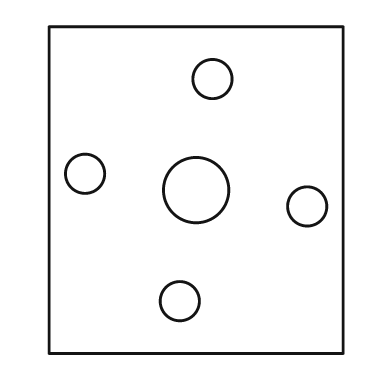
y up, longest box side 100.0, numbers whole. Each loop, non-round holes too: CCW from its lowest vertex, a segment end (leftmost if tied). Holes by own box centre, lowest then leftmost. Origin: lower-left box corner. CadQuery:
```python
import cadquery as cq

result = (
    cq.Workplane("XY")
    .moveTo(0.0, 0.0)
    .lineTo(90.0, 0.0)
    .lineTo(90.0, 100.0)
    .lineTo(0.0, 100.0)
    .close()
    .moveTo(40.0, 16.0)
    .circle(6.0)
    .moveTo(79.0, 45.0)
    .circle(6.0)
    .moveTo(45.0, 50.0)
    .circle(10.0)
    .moveTo(11.0, 55.0)
    .circle(6.0)
    .moveTo(50.0, 84.0)
    .circle(6.0)
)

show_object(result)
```